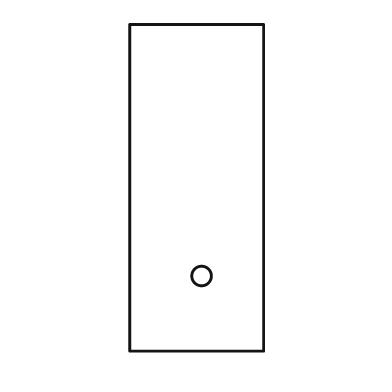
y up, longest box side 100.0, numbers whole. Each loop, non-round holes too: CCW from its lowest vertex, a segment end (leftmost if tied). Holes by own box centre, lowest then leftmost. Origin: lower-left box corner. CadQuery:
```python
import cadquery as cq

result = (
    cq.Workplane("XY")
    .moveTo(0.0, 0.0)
    .lineTo(41.0, 0.0)
    .lineTo(41.0, 100.0)
    .lineTo(0.0, 100.0)
    .close()
    .moveTo(22.0, 23.0)
    .circle(3.0)
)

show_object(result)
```